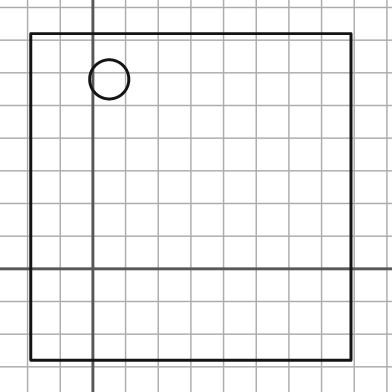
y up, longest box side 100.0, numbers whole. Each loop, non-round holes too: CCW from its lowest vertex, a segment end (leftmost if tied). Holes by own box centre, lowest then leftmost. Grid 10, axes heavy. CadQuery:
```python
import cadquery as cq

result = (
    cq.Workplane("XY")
    .moveTo(-19.0, -28.0)
    .lineTo(79.0, -28.0)
    .lineTo(79.0, 72.0)
    .lineTo(-19.0, 72.0)
    .close()
    .moveTo(5.0, 58.0)
    .circle(6.0)
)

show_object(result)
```